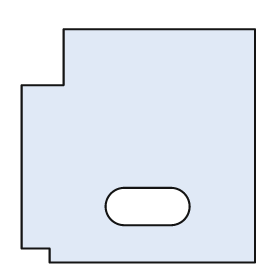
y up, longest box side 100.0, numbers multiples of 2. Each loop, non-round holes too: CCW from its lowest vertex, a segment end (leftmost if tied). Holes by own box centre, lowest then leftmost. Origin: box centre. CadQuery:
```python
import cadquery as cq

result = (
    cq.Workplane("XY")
    .moveTo(-38.0, -50.0)
    .lineTo(50.0, -50.0)
    .lineTo(50.0, 50.0)
    .lineTo(-32.0, 50.0)
    .lineTo(-32.0, 26.0)
    .lineTo(-50.0, 26.0)
    .lineTo(-50.0, -44.0)
    .lineTo(-38.0, -44.0)
    .close()
    .moveTo(-6.0, -34.0)
    .lineTo(14.0, -34.0)
    .threePointArc((22.0, -26.0), (14.0, -18.0))
    .lineTo(-6.0, -18.0)
    .threePointArc((-14.0, -26.0), (-6.0, -34.0))
    .close()
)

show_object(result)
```